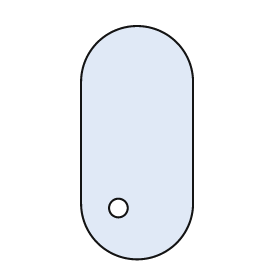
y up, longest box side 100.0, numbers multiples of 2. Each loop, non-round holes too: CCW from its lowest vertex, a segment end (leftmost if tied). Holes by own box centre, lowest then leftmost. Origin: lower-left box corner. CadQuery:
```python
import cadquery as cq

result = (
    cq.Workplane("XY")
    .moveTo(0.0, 24.0)
    .threePointArc((24.0, 0.0), (48.0, 24.0))
    .lineTo(48.0, 76.0)
    .threePointArc((24.0, 100.0), (0.0, 76.0))
    .close()
    .moveTo(16.0, 22.0)
    .circle(4.0)
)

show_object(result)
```